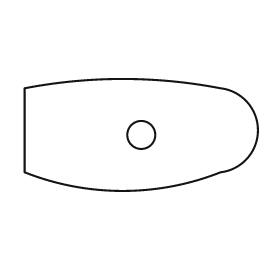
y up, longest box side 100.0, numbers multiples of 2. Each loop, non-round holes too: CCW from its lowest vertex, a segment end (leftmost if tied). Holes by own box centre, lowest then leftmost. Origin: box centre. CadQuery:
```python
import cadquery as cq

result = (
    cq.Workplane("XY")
    .moveTo(-50.0, -16.0)
    .threePointArc((-8.0, -24.0), (34.0, -16.0))
    .threePointArc((50.0, 2.0), (34.0, 20.0))
    .threePointArc((-8.0, 24.0), (-50.0, 20.0))
    .close()
    .moveTo(0.0, 0.0)
    .circle(6.0)
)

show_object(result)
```